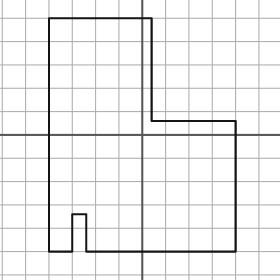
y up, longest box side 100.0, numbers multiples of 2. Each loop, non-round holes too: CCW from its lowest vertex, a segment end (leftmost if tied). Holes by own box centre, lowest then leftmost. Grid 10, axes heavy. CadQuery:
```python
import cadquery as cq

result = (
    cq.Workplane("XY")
    .moveTo(-40.0, -50.0)
    .lineTo(-30.0, -50.0)
    .lineTo(-30.0, -34.0)
    .lineTo(-24.0, -34.0)
    .lineTo(-24.0, -50.0)
    .lineTo(40.0, -50.0)
    .lineTo(40.0, 6.0)
    .lineTo(4.0, 6.0)
    .lineTo(4.0, 50.0)
    .lineTo(-40.0, 50.0)
    .close()
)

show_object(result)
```